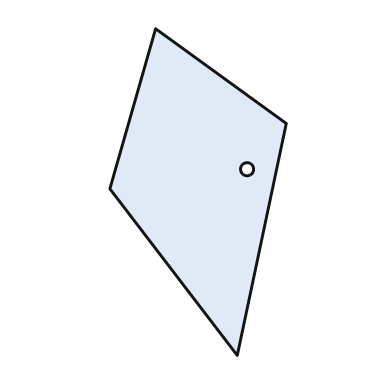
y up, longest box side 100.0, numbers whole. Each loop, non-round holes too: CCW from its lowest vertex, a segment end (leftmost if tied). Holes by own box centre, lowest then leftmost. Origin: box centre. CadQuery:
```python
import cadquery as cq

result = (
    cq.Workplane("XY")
    .moveTo(12.0, -50.0)
    .lineTo(27.0, 21.0)
    .lineTo(-13.0, 50.0)
    .lineTo(-27.0, 1.0)
    .close()
    .moveTo(15.0, 7.0)
    .circle(2.0)
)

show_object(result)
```